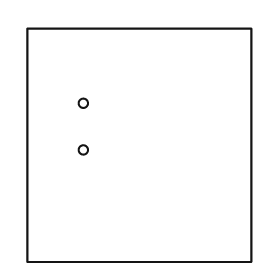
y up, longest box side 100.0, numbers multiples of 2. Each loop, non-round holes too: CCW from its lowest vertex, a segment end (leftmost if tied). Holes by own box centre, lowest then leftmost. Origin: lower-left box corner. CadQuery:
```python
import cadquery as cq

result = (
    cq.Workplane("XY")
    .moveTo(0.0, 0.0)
    .lineTo(96.0, 0.0)
    .lineTo(96.0, 100.0)
    .lineTo(0.0, 100.0)
    .close()
    .moveTo(24.0, 48.0)
    .circle(2.0)
    .moveTo(24.0, 68.0)
    .circle(2.0)
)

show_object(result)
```